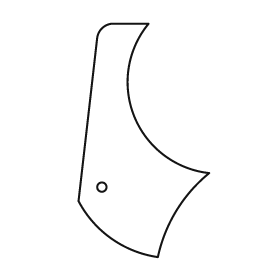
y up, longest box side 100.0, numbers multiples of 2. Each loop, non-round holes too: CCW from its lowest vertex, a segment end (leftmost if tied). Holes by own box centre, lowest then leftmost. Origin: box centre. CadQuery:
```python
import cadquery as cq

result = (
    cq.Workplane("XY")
    .moveTo(6.0, -50.0)
    .threePointArc((14.0, -30.0), (28.0, -14.0))
    .threePointArc((-4.0, 10.0), (2.0, 50.0))
    .lineTo(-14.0, 50.0)
    .threePointArc((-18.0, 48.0), (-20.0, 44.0))
    .lineTo(-28.0, -26.0)
    .threePointArc((-14.0, -42.0), (6.0, -50.0))
    .close()
    .moveTo(-18.0, -20.0)
    .circle(2.0)
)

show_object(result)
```